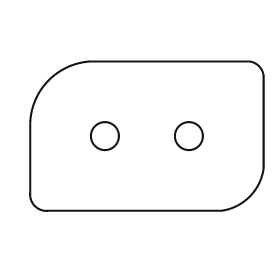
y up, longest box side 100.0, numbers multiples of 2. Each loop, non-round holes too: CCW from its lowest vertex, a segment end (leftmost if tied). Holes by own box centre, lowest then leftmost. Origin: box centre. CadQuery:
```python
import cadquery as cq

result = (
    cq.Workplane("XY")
    .moveTo(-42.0, -32.0)
    .lineTo(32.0, -32.0)
    .threePointArc((44.0, -26.0), (50.0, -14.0))
    .lineTo(50.0, 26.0)
    .threePointArc((48.0, 30.0), (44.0, 32.0))
    .lineTo(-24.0, 32.0)
    .threePointArc((-42.0, 24.0), (-50.0, 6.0))
    .lineTo(-50.0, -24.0)
    .threePointArc((-48.0, -30.0), (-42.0, -32.0))
    .close()
    .moveTo(-18.0, 0.0)
    .circle(6.0)
    .moveTo(18.0, 0.0)
    .circle(6.0)
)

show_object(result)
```